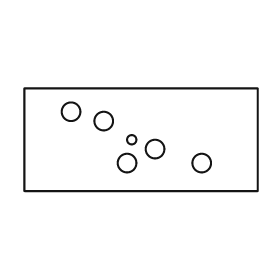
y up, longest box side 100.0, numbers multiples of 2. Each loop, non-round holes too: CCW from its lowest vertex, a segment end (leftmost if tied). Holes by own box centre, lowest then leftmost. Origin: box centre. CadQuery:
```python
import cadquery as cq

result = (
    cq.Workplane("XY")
    .moveTo(-50.0, -22.0)
    .lineTo(50.0, -22.0)
    .lineTo(50.0, 22.0)
    .lineTo(-50.0, 22.0)
    .close()
    .moveTo(-6.0, -10.0)
    .circle(4.0)
    .moveTo(26.0, -10.0)
    .circle(4.0)
    .moveTo(6.0, -4.0)
    .circle(4.0)
    .moveTo(-4.0, 0.0)
    .circle(2.0)
    .moveTo(-16.0, 8.0)
    .circle(4.0)
    .moveTo(-30.0, 12.0)
    .circle(4.0)
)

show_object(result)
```